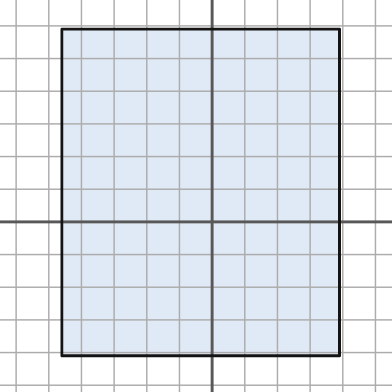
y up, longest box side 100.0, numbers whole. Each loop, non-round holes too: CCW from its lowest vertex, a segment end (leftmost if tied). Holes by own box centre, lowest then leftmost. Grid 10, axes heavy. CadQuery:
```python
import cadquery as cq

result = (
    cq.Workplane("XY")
    .moveTo(-46.0, -41.0)
    .lineTo(39.0, -41.0)
    .lineTo(39.0, 59.0)
    .lineTo(-46.0, 59.0)
    .close()
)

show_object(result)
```